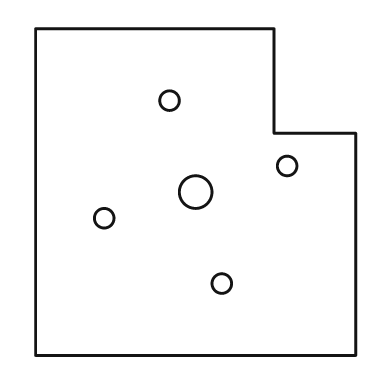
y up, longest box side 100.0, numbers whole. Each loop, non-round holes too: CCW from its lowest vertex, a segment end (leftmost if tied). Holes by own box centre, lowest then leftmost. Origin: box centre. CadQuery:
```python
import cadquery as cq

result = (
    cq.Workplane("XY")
    .moveTo(-49.0, -50.0)
    .lineTo(49.0, -50.0)
    .lineTo(49.0, 18.0)
    .lineTo(24.0, 18.0)
    .lineTo(24.0, 50.0)
    .lineTo(-49.0, 50.0)
    .close()
    .moveTo(8.0, -28.0)
    .circle(3.0)
    .moveTo(-28.0, -8.0)
    .circle(3.0)
    .moveTo(0.0, 0.0)
    .circle(5.0)
    .moveTo(28.0, 8.0)
    .circle(3.0)
    .moveTo(-8.0, 28.0)
    .circle(3.0)
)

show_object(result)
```